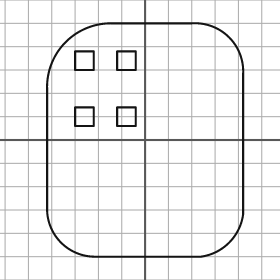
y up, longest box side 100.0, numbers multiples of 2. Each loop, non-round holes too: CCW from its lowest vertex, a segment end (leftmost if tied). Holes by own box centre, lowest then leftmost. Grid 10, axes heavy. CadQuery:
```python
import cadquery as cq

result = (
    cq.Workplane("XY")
    .moveTo(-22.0, -50.0)
    .lineTo(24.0, -50.0)
    .threePointArc((36.0, -44.0), (42.0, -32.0))
    .lineTo(42.0, 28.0)
    .threePointArc((36.0, 44.0), (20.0, 50.0))
    .lineTo(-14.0, 50.0)
    .threePointArc((-34.0, 42.0), (-42.0, 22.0))
    .lineTo(-42.0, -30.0)
    .threePointArc((-36.0, -44.0), (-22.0, -50.0))
    .close()
    .moveTo(-30.0, 6.0)
    .lineTo(-22.0, 6.0)
    .lineTo(-22.0, 14.0)
    .lineTo(-30.0, 14.0)
    .close()
    .moveTo(-12.0, 6.0)
    .lineTo(-4.0, 6.0)
    .lineTo(-4.0, 14.0)
    .lineTo(-12.0, 14.0)
    .close()
    .moveTo(-30.0, 30.0)
    .lineTo(-22.0, 30.0)
    .lineTo(-22.0, 38.0)
    .lineTo(-30.0, 38.0)
    .close()
    .moveTo(-12.0, 30.0)
    .lineTo(-4.0, 30.0)
    .lineTo(-4.0, 38.0)
    .lineTo(-12.0, 38.0)
    .close()
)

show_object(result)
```